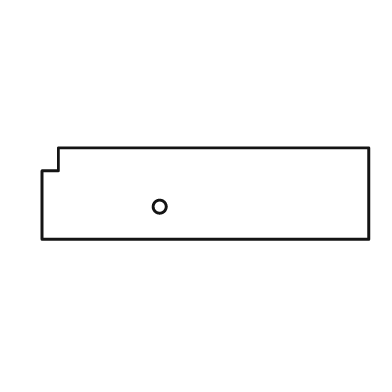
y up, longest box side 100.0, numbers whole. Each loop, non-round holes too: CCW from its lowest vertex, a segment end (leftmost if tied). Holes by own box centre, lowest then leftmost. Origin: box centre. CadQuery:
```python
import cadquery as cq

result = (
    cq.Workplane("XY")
    .moveTo(-50.0, -14.0)
    .lineTo(50.0, -14.0)
    .lineTo(50.0, 14.0)
    .lineTo(-45.0, 14.0)
    .lineTo(-45.0, 7.0)
    .lineTo(-50.0, 7.0)
    .close()
    .moveTo(-14.0, -4.0)
    .circle(2.0)
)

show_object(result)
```